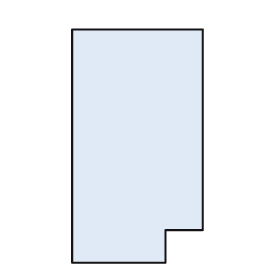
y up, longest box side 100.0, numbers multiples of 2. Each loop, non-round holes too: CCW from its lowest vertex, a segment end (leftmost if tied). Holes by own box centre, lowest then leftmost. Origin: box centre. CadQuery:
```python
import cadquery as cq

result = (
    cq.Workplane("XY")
    .moveTo(-28.0, -50.0)
    .lineTo(12.0, -50.0)
    .lineTo(12.0, -36.0)
    .lineTo(28.0, -36.0)
    .lineTo(28.0, 50.0)
    .lineTo(-28.0, 50.0)
    .close()
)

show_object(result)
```